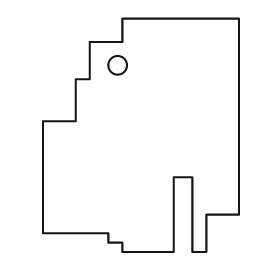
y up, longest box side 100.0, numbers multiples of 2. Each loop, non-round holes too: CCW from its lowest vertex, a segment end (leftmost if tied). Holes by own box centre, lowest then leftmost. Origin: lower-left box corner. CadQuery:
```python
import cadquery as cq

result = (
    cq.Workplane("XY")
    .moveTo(34.0, 0.0)
    .lineTo(56.0, 0.0)
    .lineTo(56.0, 32.0)
    .lineTo(64.0, 32.0)
    .lineTo(64.0, 0.0)
    .lineTo(70.0, 0.0)
    .lineTo(70.0, 16.0)
    .lineTo(84.0, 16.0)
    .lineTo(84.0, 100.0)
    .lineTo(34.0, 100.0)
    .lineTo(34.0, 90.0)
    .lineTo(20.0, 90.0)
    .lineTo(20.0, 74.0)
    .lineTo(14.0, 74.0)
    .lineTo(14.0, 56.0)
    .lineTo(0.0, 56.0)
    .lineTo(0.0, 8.0)
    .lineTo(28.0, 8.0)
    .lineTo(28.0, 4.0)
    .lineTo(34.0, 4.0)
    .close()
    .moveTo(32.0, 80.0)
    .circle(4.0)
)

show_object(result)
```